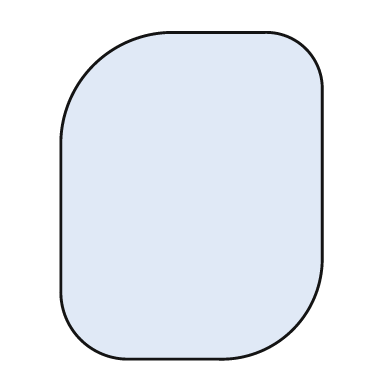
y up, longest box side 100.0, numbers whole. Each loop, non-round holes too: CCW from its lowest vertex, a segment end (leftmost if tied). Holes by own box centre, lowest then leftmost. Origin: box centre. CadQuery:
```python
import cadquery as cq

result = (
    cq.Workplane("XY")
    .moveTo(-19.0, -50.0)
    .lineTo(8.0, -50.0)
    .threePointArc((31.0, -41.0), (40.0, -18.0))
    .lineTo(40.0, 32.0)
    .threePointArc((35.0, 45.0), (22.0, 50.0))
    .lineTo(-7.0, 50.0)
    .threePointArc((-30.0, 40.0), (-40.0, 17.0))
    .lineTo(-40.0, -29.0)
    .threePointArc((-34.0, -44.0), (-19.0, -50.0))
    .close()
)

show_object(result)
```